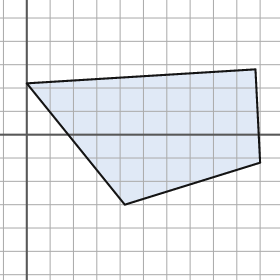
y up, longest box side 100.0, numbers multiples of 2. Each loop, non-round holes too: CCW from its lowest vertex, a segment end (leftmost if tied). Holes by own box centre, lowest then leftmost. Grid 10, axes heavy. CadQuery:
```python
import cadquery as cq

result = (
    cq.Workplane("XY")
    .moveTo(42.0, -30.0)
    .lineTo(100.0, -12.0)
    .lineTo(98.0, 28.0)
    .lineTo(0.0, 22.0)
    .close()
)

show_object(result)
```